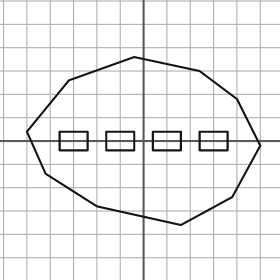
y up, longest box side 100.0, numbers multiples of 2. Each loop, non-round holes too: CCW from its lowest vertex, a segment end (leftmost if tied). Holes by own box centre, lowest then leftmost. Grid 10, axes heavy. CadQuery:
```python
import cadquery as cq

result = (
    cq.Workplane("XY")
    .moveTo(16.0, -36.0)
    .lineTo(38.0, -24.0)
    .lineTo(50.0, -2.0)
    .lineTo(40.0, 18.0)
    .lineTo(24.0, 30.0)
    .lineTo(-4.0, 36.0)
    .lineTo(-32.0, 26.0)
    .lineTo(-50.0, 4.0)
    .lineTo(-42.0, -14.0)
    .lineTo(-20.0, -28.0)
    .close()
    .moveTo(-36.0, -4.0)
    .lineTo(-24.0, -4.0)
    .lineTo(-24.0, 4.0)
    .lineTo(-36.0, 4.0)
    .close()
    .moveTo(-16.0, -4.0)
    .lineTo(-4.0, -4.0)
    .lineTo(-4.0, 4.0)
    .lineTo(-16.0, 4.0)
    .close()
    .moveTo(4.0, -4.0)
    .lineTo(16.0, -4.0)
    .lineTo(16.0, 4.0)
    .lineTo(4.0, 4.0)
    .close()
    .moveTo(24.0, -4.0)
    .lineTo(36.0, -4.0)
    .lineTo(36.0, 4.0)
    .lineTo(24.0, 4.0)
    .close()
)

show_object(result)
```